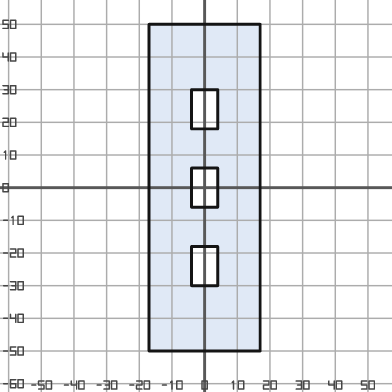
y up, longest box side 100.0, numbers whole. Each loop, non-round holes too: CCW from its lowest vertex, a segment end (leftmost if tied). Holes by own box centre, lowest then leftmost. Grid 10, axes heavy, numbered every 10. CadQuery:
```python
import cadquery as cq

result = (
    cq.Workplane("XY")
    .moveTo(-17.0, -50.0)
    .lineTo(17.0, -50.0)
    .lineTo(17.0, 50.0)
    .lineTo(-17.0, 50.0)
    .close()
    .moveTo(-4.0, -30.0)
    .lineTo(4.0, -30.0)
    .lineTo(4.0, -18.0)
    .lineTo(-4.0, -18.0)
    .close()
    .moveTo(-4.0, -6.0)
    .lineTo(4.0, -6.0)
    .lineTo(4.0, 6.0)
    .lineTo(-4.0, 6.0)
    .close()
    .moveTo(-4.0, 18.0)
    .lineTo(4.0, 18.0)
    .lineTo(4.0, 30.0)
    .lineTo(-4.0, 30.0)
    .close()
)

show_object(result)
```